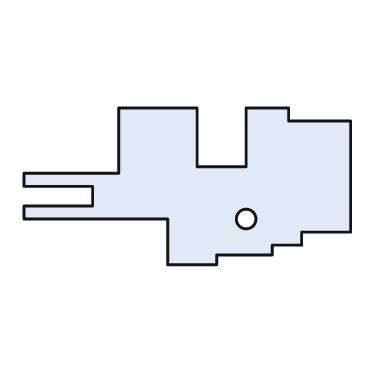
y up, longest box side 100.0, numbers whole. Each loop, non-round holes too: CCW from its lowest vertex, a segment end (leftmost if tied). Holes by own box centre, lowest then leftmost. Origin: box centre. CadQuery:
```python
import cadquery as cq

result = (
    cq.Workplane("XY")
    .moveTo(-6.0, -24.0)
    .lineTo(9.0, -24.0)
    .lineTo(9.0, -21.0)
    .lineTo(26.0, -21.0)
    .lineTo(26.0, -18.0)
    .lineTo(35.0, -18.0)
    .lineTo(35.0, -14.0)
    .lineTo(50.0, -14.0)
    .lineTo(50.0, 20.0)
    .lineTo(31.0, 20.0)
    .lineTo(31.0, 24.0)
    .lineTo(18.0, 24.0)
    .lineTo(18.0, 6.0)
    .lineTo(3.0, 6.0)
    .lineTo(3.0, 24.0)
    .lineTo(-21.0, 24.0)
    .lineTo(-21.0, 4.0)
    .lineTo(-50.0, 4.0)
    .lineTo(-50.0, 0.0)
    .lineTo(-29.0, 0.0)
    .lineTo(-29.0, -6.0)
    .lineTo(-50.0, -6.0)
    .lineTo(-50.0, -10.0)
    .lineTo(-6.0, -10.0)
    .close()
    .moveTo(18.0, -10.0)
    .circle(3.0)
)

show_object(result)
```